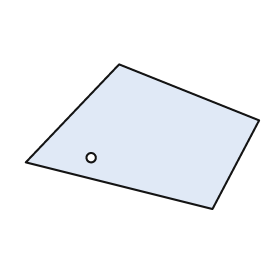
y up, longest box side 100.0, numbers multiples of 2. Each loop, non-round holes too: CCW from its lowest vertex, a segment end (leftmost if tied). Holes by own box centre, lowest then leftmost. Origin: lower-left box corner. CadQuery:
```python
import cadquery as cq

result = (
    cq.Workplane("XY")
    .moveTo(80.0, 0.0)
    .lineTo(100.0, 38.0)
    .lineTo(40.0, 62.0)
    .lineTo(0.0, 20.0)
    .close()
    .moveTo(28.0, 22.0)
    .circle(2.0)
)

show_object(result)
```